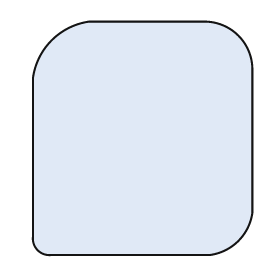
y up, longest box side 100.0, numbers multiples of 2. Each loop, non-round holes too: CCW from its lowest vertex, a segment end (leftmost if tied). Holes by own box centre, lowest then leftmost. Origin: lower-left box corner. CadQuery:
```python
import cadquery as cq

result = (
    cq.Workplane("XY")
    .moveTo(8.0, 0.0)
    .lineTo(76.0, 0.0)
    .threePointArc((88.0, 6.0), (94.0, 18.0))
    .lineTo(94.0, 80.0)
    .threePointArc((88.0, 94.0), (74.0, 100.0))
    .lineTo(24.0, 100.0)
    .threePointArc((8.0, 92.0), (0.0, 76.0))
    .lineTo(0.0, 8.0)
    .threePointArc((2.0, 2.0), (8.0, 0.0))
    .close()
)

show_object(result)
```